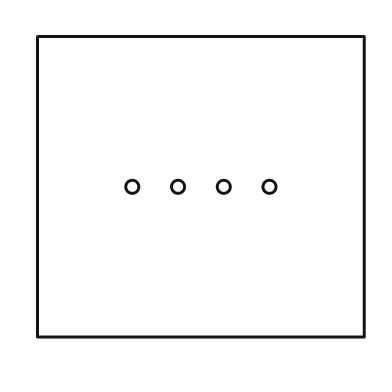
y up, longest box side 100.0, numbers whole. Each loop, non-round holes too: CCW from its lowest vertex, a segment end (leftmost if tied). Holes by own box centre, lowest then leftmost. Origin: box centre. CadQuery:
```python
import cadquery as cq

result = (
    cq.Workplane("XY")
    .moveTo(-50.0, -46.0)
    .lineTo(50.0, -46.0)
    .lineTo(50.0, 46.0)
    .lineTo(-50.0, 46.0)
    .close()
    .moveTo(-21.0, 0.0)
    .circle(2.0)
    .moveTo(-7.0, 0.0)
    .circle(2.0)
    .moveTo(7.0, 0.0)
    .circle(2.0)
    .moveTo(21.0, 0.0)
    .circle(2.0)
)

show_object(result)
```